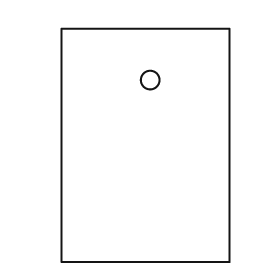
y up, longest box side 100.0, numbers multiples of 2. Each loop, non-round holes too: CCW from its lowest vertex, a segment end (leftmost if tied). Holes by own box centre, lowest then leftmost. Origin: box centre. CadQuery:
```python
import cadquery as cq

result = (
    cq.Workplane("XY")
    .moveTo(-36.0, -50.0)
    .lineTo(36.0, -50.0)
    .lineTo(36.0, 50.0)
    .lineTo(-36.0, 50.0)
    .close()
    .moveTo(2.0, 28.0)
    .circle(4.0)
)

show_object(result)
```